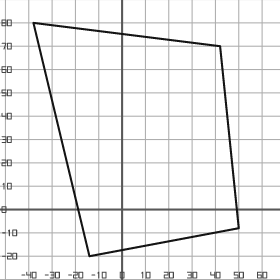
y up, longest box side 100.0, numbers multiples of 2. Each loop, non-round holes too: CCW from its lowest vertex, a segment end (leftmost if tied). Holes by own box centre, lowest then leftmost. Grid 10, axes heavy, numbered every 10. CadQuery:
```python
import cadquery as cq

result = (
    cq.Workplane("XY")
    .moveTo(-14.0, -20.0)
    .lineTo(50.0, -8.0)
    .lineTo(42.0, 70.0)
    .lineTo(-38.0, 80.0)
    .close()
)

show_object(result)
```